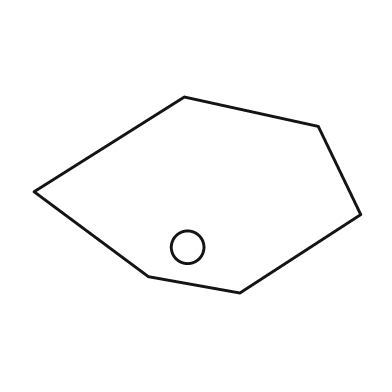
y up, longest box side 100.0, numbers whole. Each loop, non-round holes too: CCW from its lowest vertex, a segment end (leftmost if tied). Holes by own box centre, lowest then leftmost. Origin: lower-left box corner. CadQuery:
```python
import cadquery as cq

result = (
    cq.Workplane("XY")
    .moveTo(63.0, 0.0)
    .lineTo(100.0, 24.0)
    .lineTo(87.0, 51.0)
    .lineTo(46.0, 60.0)
    .lineTo(0.0, 31.0)
    .lineTo(35.0, 5.0)
    .close()
    .moveTo(47.0, 14.0)
    .circle(5.0)
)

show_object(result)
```